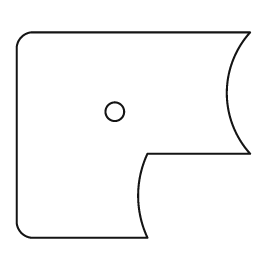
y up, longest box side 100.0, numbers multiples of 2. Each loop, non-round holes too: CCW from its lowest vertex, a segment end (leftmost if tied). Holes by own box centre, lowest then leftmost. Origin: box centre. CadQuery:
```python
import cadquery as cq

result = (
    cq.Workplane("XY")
    .moveTo(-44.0, -44.0)
    .lineTo(6.0, -44.0)
    .threePointArc((2.0, -26.0), (6.0, -8.0))
    .lineTo(50.0, -8.0)
    .threePointArc((40.0, 18.0), (50.0, 44.0))
    .lineTo(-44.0, 44.0)
    .threePointArc((-48.0, 42.0), (-50.0, 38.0))
    .lineTo(-50.0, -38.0)
    .threePointArc((-48.0, -42.0), (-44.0, -44.0))
    .close()
    .moveTo(-8.0, 10.0)
    .circle(4.0)
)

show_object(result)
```